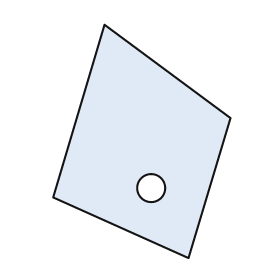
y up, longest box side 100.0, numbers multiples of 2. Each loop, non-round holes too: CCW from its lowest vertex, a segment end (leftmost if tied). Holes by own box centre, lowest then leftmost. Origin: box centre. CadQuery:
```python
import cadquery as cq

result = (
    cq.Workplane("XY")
    .moveTo(20.0, -50.0)
    .lineTo(38.0, 10.0)
    .lineTo(-16.0, 50.0)
    .lineTo(-38.0, -24.0)
    .close()
    .moveTo(4.0, -20.0)
    .circle(6.0)
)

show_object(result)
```